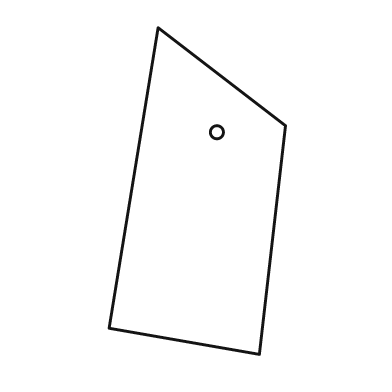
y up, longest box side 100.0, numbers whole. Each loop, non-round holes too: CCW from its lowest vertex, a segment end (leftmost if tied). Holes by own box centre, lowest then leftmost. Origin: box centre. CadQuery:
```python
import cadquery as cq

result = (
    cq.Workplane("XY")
    .moveTo(19.0, -50.0)
    .lineTo(27.0, 20.0)
    .lineTo(-12.0, 50.0)
    .lineTo(-27.0, -42.0)
    .close()
    .moveTo(6.0, 18.0)
    .circle(2.0)
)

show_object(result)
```